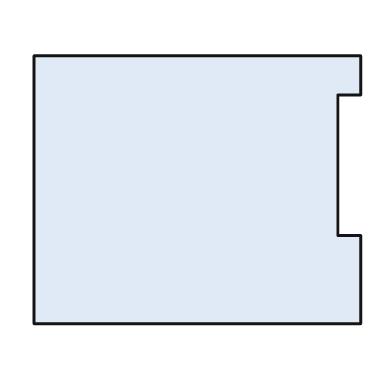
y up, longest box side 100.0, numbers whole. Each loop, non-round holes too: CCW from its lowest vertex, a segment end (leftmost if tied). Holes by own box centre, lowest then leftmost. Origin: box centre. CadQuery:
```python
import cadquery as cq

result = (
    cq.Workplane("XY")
    .moveTo(-50.0, -41.0)
    .lineTo(50.0, -41.0)
    .lineTo(50.0, -14.0)
    .lineTo(43.0, -14.0)
    .lineTo(43.0, 29.0)
    .lineTo(50.0, 29.0)
    .lineTo(50.0, 41.0)
    .lineTo(-50.0, 41.0)
    .close()
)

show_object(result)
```